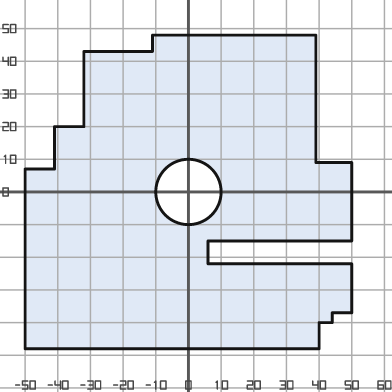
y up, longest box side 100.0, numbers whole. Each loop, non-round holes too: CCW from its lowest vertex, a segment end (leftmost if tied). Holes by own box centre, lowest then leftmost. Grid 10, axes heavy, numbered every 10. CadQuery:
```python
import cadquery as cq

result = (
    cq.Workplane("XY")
    .moveTo(-50.0, -48.0)
    .lineTo(40.0, -48.0)
    .lineTo(40.0, -40.0)
    .lineTo(44.0, -40.0)
    .lineTo(44.0, -37.0)
    .lineTo(50.0, -37.0)
    .lineTo(50.0, -22.0)
    .lineTo(6.0, -22.0)
    .lineTo(6.0, -15.0)
    .lineTo(50.0, -15.0)
    .lineTo(50.0, 9.0)
    .lineTo(39.0, 9.0)
    .lineTo(39.0, 48.0)
    .lineTo(-11.0, 48.0)
    .lineTo(-11.0, 43.0)
    .lineTo(-32.0, 43.0)
    .lineTo(-32.0, 20.0)
    .lineTo(-41.0, 20.0)
    .lineTo(-41.0, 7.0)
    .lineTo(-50.0, 7.0)
    .close()
    .moveTo(0.0, 0.0)
    .circle(10.0)
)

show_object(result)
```